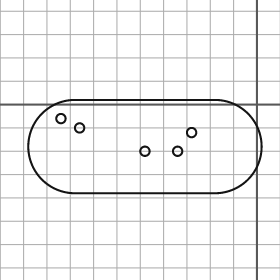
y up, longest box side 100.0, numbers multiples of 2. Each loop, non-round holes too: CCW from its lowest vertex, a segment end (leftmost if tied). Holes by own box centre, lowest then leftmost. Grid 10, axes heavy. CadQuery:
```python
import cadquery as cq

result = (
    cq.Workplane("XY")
    .moveTo(-78.0, -38.0)
    .lineTo(-18.0, -38.0)
    .threePointArc((2.0, -18.0), (-18.0, 2.0))
    .lineTo(-78.0, 2.0)
    .threePointArc((-98.0, -18.0), (-78.0, -38.0))
    .close()
    .moveTo(-48.0, -20.0)
    .circle(2.0)
    .moveTo(-34.0, -20.0)
    .circle(2.0)
    .moveTo(-28.0, -12.0)
    .circle(2.0)
    .moveTo(-76.0, -10.0)
    .circle(2.0)
    .moveTo(-84.0, -6.0)
    .circle(2.0)
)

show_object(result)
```